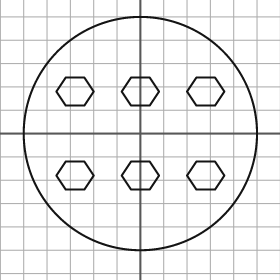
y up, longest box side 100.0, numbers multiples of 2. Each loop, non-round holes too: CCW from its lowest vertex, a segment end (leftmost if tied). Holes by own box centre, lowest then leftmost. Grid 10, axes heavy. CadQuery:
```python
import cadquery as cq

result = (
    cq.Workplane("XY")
    .moveTo(0.0, 0.0)
    .circle(50.0)
    .moveTo(-32.0, -24.0)
    .lineTo(-24.0, -24.0)
    .lineTo(-20.0, -18.0)
    .lineTo(-24.0, -12.0)
    .lineTo(-32.0, -12.0)
    .lineTo(-36.0, -18.0)
    .close()
    .moveTo(-4.0, -24.0)
    .lineTo(4.0, -24.0)
    .lineTo(8.0, -18.0)
    .lineTo(4.0, -12.0)
    .lineTo(-4.0, -12.0)
    .lineTo(-8.0, -18.0)
    .close()
    .moveTo(24.0, -24.0)
    .lineTo(32.0, -24.0)
    .lineTo(36.0, -18.0)
    .lineTo(32.0, -12.0)
    .lineTo(24.0, -12.0)
    .lineTo(20.0, -18.0)
    .close()
    .moveTo(-32.0, 12.0)
    .lineTo(-24.0, 12.0)
    .lineTo(-20.0, 18.0)
    .lineTo(-24.0, 24.0)
    .lineTo(-32.0, 24.0)
    .lineTo(-36.0, 18.0)
    .close()
    .moveTo(-4.0, 12.0)
    .lineTo(4.0, 12.0)
    .lineTo(8.0, 18.0)
    .lineTo(4.0, 24.0)
    .lineTo(-4.0, 24.0)
    .lineTo(-8.0, 18.0)
    .close()
    .moveTo(24.0, 12.0)
    .lineTo(32.0, 12.0)
    .lineTo(36.0, 18.0)
    .lineTo(32.0, 24.0)
    .lineTo(24.0, 24.0)
    .lineTo(20.0, 18.0)
    .close()
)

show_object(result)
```